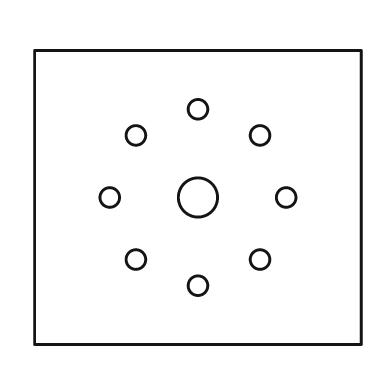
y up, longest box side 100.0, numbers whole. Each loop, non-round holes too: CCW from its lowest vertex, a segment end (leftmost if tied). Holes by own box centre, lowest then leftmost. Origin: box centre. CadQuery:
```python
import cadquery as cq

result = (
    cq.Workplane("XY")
    .moveTo(-50.0, -45.0)
    .lineTo(50.0, -45.0)
    .lineTo(50.0, 45.0)
    .lineTo(-50.0, 45.0)
    .close()
    .moveTo(0.0, -27.0)
    .circle(3.0)
    .moveTo(-19.0, -19.0)
    .circle(3.0)
    .moveTo(19.0, -19.0)
    .circle(3.0)
    .moveTo(-27.0, 0.0)
    .circle(3.0)
    .moveTo(0.0, 0.0)
    .circle(6.0)
    .moveTo(27.0, 0.0)
    .circle(3.0)
    .moveTo(-19.0, 19.0)
    .circle(3.0)
    .moveTo(19.0, 19.0)
    .circle(3.0)
    .moveTo(0.0, 27.0)
    .circle(3.0)
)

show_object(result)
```